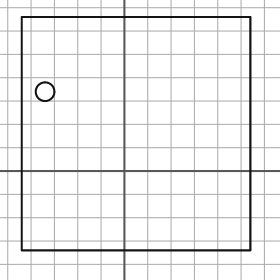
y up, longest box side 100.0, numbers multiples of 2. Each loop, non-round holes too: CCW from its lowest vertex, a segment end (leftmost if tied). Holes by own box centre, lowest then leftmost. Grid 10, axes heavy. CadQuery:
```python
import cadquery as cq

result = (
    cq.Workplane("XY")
    .moveTo(-44.0, -34.0)
    .lineTo(54.0, -34.0)
    .lineTo(54.0, 66.0)
    .lineTo(-44.0, 66.0)
    .close()
    .moveTo(-34.0, 34.0)
    .circle(4.0)
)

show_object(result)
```